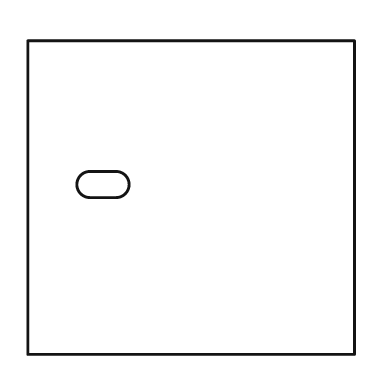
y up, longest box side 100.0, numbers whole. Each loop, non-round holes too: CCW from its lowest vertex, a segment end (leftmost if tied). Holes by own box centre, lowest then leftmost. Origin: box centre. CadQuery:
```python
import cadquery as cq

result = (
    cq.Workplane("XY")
    .moveTo(-50.0, -48.0)
    .lineTo(50.0, -48.0)
    .lineTo(50.0, 48.0)
    .lineTo(-50.0, 48.0)
    .close()
    .moveTo(-31.0, 0.0)
    .lineTo(-23.0, 0.0)
    .threePointArc((-19.0, 4.0), (-23.0, 8.0))
    .lineTo(-31.0, 8.0)
    .threePointArc((-35.0, 4.0), (-31.0, 0.0))
    .close()
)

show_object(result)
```